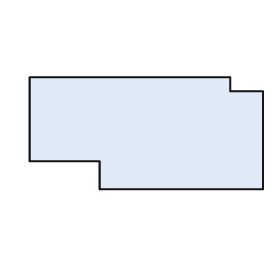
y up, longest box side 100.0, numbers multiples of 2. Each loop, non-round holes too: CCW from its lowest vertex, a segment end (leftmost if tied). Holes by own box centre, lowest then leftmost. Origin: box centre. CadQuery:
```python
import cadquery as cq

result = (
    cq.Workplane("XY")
    .moveTo(-20.0, -24.0)
    .lineTo(50.0, -24.0)
    .lineTo(50.0, 18.0)
    .lineTo(36.0, 18.0)
    .lineTo(36.0, 24.0)
    .lineTo(-50.0, 24.0)
    .lineTo(-50.0, -12.0)
    .lineTo(-20.0, -12.0)
    .close()
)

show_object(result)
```